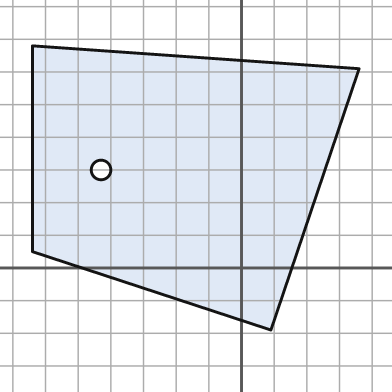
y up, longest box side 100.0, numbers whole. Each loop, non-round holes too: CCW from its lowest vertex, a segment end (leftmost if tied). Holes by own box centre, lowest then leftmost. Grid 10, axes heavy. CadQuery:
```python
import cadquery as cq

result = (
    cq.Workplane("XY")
    .moveTo(9.0, -19.0)
    .lineTo(36.0, 61.0)
    .lineTo(-64.0, 68.0)
    .lineTo(-64.0, 5.0)
    .close()
    .moveTo(-43.0, 30.0)
    .circle(3.0)
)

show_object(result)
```